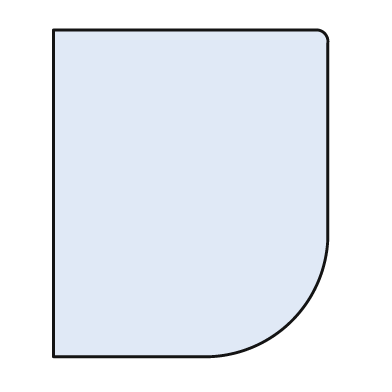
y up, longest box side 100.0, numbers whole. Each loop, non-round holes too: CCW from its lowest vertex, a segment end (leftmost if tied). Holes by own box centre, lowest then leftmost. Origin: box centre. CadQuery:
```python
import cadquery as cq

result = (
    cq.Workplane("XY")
    .moveTo(-42.0, -50.0)
    .lineTo(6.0, -50.0)
    .threePointArc((31.0, -39.0), (42.0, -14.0))
    .lineTo(42.0, 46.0)
    .threePointArc((41.0, 49.0), (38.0, 50.0))
    .lineTo(-42.0, 50.0)
    .close()
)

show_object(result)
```